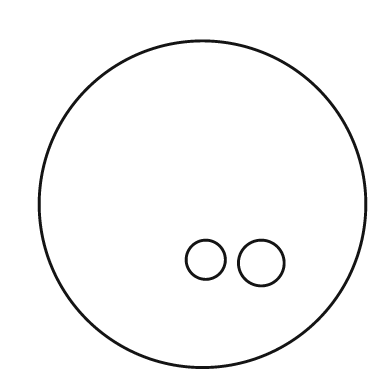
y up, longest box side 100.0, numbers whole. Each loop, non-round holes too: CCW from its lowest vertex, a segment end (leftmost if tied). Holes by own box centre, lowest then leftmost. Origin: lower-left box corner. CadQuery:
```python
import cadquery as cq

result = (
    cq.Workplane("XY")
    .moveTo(50.0, 50.0)
    .circle(50.0)
    .moveTo(68.0, 32.0)
    .circle(7.0)
    .moveTo(51.0, 33.0)
    .circle(6.0)
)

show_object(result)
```